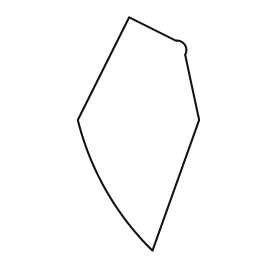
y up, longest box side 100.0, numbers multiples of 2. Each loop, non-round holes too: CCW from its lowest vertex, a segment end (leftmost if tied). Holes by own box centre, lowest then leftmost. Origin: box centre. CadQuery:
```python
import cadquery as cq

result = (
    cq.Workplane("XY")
    .moveTo(6.0, -50.0)
    .lineTo(26.0, 6.0)
    .lineTo(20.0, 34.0)
    .threePointArc((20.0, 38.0), (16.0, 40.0))
    .lineTo(-4.0, 50.0)
    .lineTo(-26.0, 6.0)
    .threePointArc((-14.0, -24.0), (6.0, -50.0))
    .close()
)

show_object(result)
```